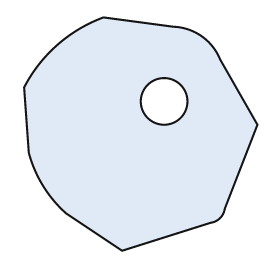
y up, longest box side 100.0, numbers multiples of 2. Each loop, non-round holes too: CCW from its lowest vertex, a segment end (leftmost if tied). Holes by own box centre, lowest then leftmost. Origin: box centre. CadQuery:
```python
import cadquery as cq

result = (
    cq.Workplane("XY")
    .moveTo(-8.0, -50.0)
    .lineTo(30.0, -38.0)
    .threePointArc((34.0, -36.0), (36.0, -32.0))
    .lineTo(50.0, 4.0)
    .lineTo(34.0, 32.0)
    .threePointArc((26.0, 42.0), (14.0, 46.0))
    .lineTo(-16.0, 50.0)
    .threePointArc((-36.0, 38.0), (-50.0, 20.0))
    .lineTo(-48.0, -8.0)
    .threePointArc((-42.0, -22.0), (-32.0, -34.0))
    .close()
    .moveTo(10.0, 14.0)
    .circle(10.0)
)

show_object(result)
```